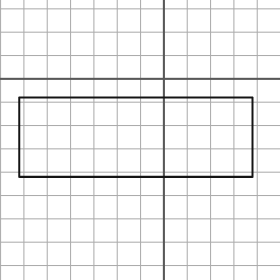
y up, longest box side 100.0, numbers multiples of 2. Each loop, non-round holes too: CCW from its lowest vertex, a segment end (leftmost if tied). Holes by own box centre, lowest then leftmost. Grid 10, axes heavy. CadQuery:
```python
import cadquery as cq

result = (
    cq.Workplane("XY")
    .moveTo(-62.0, -42.0)
    .lineTo(38.0, -42.0)
    .lineTo(38.0, -8.0)
    .lineTo(-62.0, -8.0)
    .close()
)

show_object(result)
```